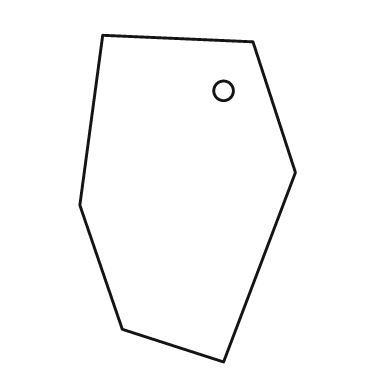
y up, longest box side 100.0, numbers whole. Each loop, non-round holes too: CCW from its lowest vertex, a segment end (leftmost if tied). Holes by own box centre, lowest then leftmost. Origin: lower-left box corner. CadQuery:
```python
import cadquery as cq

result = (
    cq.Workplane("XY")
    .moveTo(44.0, 0.0)
    .lineTo(66.0, 58.0)
    .lineTo(53.0, 98.0)
    .lineTo(7.0, 100.0)
    .lineTo(0.0, 48.0)
    .lineTo(13.0, 10.0)
    .close()
    .moveTo(44.0, 83.0)
    .circle(3.0)
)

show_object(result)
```